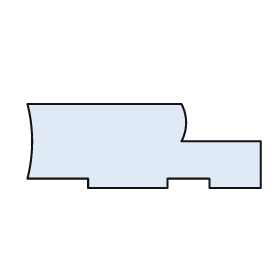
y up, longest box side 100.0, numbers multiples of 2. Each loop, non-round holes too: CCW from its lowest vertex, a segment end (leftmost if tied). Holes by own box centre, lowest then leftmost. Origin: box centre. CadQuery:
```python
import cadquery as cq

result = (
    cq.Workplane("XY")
    .moveTo(-24.0, -18.0)
    .lineTo(10.0, -18.0)
    .lineTo(10.0, -14.0)
    .lineTo(28.0, -14.0)
    .lineTo(28.0, -18.0)
    .lineTo(50.0, -18.0)
    .lineTo(50.0, 2.0)
    .lineTo(16.0, 2.0)
    .threePointArc((18.0, 10.0), (16.0, 18.0))
    .lineTo(-50.0, 18.0)
    .threePointArc((-48.0, 2.0), (-50.0, -14.0))
    .lineTo(-24.0, -14.0)
    .close()
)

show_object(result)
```